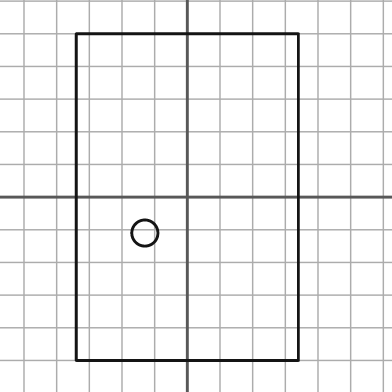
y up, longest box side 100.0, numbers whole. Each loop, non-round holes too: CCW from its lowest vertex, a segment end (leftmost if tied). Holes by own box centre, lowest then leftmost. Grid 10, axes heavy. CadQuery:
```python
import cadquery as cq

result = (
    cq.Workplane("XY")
    .moveTo(-34.0, -50.0)
    .lineTo(34.0, -50.0)
    .lineTo(34.0, 50.0)
    .lineTo(-34.0, 50.0)
    .close()
    .moveTo(-13.0, -11.0)
    .circle(4.0)
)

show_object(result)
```